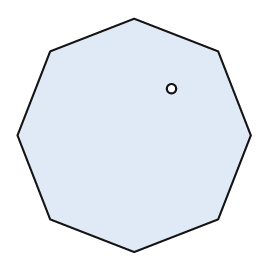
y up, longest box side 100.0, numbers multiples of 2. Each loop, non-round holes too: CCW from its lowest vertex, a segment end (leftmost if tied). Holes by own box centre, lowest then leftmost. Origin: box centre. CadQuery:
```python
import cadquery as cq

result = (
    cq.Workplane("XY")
    .moveTo(0.0, -50.0)
    .lineTo(36.0, -36.0)
    .lineTo(50.0, 0.0)
    .lineTo(36.0, 36.0)
    .lineTo(0.0, 50.0)
    .lineTo(-36.0, 36.0)
    .lineTo(-50.0, 0.0)
    .lineTo(-36.0, -36.0)
    .close()
    .moveTo(16.0, 20.0)
    .circle(2.0)
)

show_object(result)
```